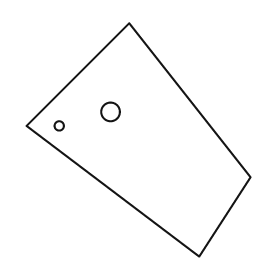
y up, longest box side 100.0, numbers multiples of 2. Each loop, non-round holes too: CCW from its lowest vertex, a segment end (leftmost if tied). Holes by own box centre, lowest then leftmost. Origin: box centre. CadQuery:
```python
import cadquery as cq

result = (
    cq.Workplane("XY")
    .moveTo(26.0, -50.0)
    .lineTo(48.0, -16.0)
    .lineTo(-4.0, 50.0)
    .lineTo(-48.0, 6.0)
    .close()
    .moveTo(-34.0, 6.0)
    .circle(2.0)
    .moveTo(-12.0, 12.0)
    .circle(4.0)
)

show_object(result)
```